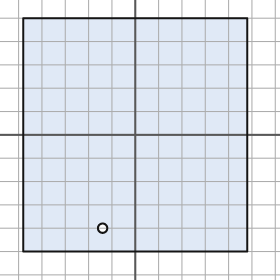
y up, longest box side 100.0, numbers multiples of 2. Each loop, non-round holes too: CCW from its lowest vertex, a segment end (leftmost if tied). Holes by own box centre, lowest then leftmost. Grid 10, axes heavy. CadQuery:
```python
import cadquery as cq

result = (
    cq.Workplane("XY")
    .moveTo(-48.0, -50.0)
    .lineTo(48.0, -50.0)
    .lineTo(48.0, 50.0)
    .lineTo(-48.0, 50.0)
    .close()
    .moveTo(-14.0, -40.0)
    .circle(2.0)
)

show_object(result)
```